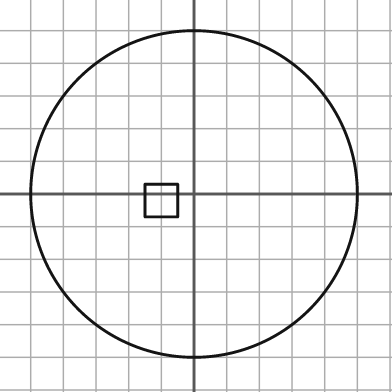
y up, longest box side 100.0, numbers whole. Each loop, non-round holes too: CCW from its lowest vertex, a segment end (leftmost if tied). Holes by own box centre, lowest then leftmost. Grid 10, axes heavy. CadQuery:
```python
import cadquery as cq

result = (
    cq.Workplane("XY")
    .moveTo(0.0, 0.0)
    .circle(50.0)
    .moveTo(-15.0, -7.0)
    .lineTo(-5.0, -7.0)
    .lineTo(-5.0, 3.0)
    .lineTo(-15.0, 3.0)
    .close()
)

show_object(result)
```